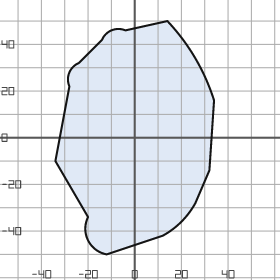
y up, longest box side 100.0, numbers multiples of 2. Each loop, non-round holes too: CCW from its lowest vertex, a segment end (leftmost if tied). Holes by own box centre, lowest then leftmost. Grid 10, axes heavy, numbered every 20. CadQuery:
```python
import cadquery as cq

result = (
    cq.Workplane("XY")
    .moveTo(-12.0, -50.0)
    .lineTo(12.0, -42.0)
    .threePointArc((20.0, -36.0), (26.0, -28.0))
    .lineTo(32.0, -14.0)
    .lineTo(34.0, 16.0)
    .threePointArc((26.0, 34.0), (14.0, 50.0))
    .lineTo(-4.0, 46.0)
    .threePointArc((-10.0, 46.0), (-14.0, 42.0))
    .lineTo(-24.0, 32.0)
    .threePointArc((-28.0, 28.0), (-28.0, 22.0))
    .lineTo(-34.0, -10.0)
    .lineTo(-20.0, -34.0)
    .threePointArc((-20.0, -44.0), (-12.0, -50.0))
    .close()
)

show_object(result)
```